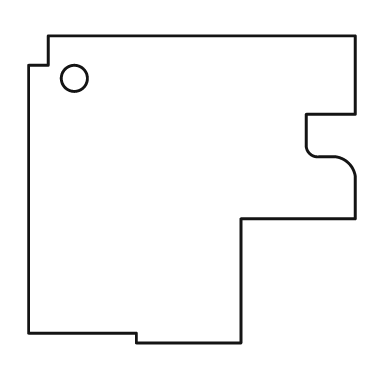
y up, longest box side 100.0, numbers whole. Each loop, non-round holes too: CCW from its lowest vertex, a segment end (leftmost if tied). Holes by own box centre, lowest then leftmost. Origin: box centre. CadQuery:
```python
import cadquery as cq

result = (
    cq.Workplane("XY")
    .moveTo(-17.0, -47.0)
    .lineTo(15.0, -47.0)
    .lineTo(15.0, -9.0)
    .lineTo(50.0, -9.0)
    .lineTo(50.0, 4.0)
    .threePointArc((48.0, 8.0), (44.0, 10.0))
    .lineTo(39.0, 10.0)
    .threePointArc((36.0, 11.0), (35.0, 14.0))
    .lineTo(35.0, 23.0)
    .lineTo(50.0, 23.0)
    .lineTo(50.0, 47.0)
    .lineTo(-44.0, 47.0)
    .lineTo(-44.0, 38.0)
    .lineTo(-50.0, 38.0)
    .lineTo(-50.0, -44.0)
    .lineTo(-17.0, -44.0)
    .close()
    .moveTo(-36.0, 34.0)
    .circle(4.0)
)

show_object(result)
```